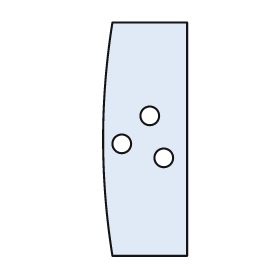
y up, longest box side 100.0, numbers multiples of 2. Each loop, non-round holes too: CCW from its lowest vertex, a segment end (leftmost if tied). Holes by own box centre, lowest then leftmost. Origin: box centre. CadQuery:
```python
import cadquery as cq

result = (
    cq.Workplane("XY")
    .moveTo(-14.0, -50.0)
    .lineTo(18.0, -50.0)
    .lineTo(18.0, 50.0)
    .lineTo(-14.0, 50.0)
    .threePointArc((-18.0, 0.0), (-14.0, -50.0))
    .close()
    .moveTo(8.0, -8.0)
    .circle(4.0)
    .moveTo(-10.0, -2.0)
    .circle(4.0)
    .moveTo(2.0, 10.0)
    .circle(4.0)
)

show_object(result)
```